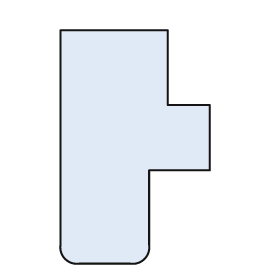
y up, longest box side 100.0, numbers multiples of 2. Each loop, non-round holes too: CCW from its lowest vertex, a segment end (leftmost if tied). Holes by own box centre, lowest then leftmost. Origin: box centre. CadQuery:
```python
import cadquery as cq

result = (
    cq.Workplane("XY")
    .moveTo(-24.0, -50.0)
    .lineTo(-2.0, -50.0)
    .threePointArc((4.0, -48.0), (6.0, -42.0))
    .lineTo(6.0, -10.0)
    .lineTo(32.0, -10.0)
    .lineTo(32.0, 18.0)
    .lineTo(14.0, 18.0)
    .lineTo(14.0, 50.0)
    .lineTo(-32.0, 50.0)
    .lineTo(-32.0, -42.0)
    .threePointArc((-30.0, -48.0), (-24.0, -50.0))
    .close()
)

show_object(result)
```